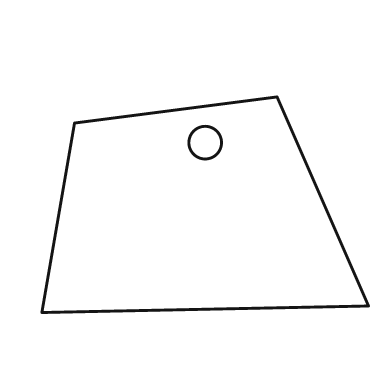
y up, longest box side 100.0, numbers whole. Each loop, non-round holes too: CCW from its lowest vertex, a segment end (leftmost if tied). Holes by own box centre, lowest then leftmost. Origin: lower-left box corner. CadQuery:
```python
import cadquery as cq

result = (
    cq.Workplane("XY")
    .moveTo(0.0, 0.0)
    .lineTo(100.0, 2.0)
    .lineTo(72.0, 66.0)
    .lineTo(10.0, 58.0)
    .close()
    .moveTo(50.0, 52.0)
    .circle(5.0)
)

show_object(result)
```